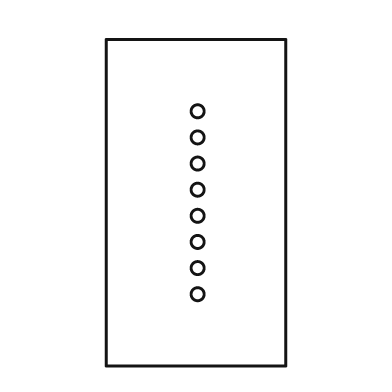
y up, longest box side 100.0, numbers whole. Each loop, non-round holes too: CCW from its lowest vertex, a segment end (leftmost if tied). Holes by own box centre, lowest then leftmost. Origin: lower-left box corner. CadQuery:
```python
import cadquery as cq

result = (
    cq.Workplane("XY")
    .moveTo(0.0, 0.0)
    .lineTo(55.0, 0.0)
    .lineTo(55.0, 100.0)
    .lineTo(0.0, 100.0)
    .close()
    .moveTo(28.0, 22.0)
    .circle(2.0)
    .moveTo(28.0, 30.0)
    .circle(2.0)
    .moveTo(28.0, 38.0)
    .circle(2.0)
    .moveTo(28.0, 46.0)
    .circle(2.0)
    .moveTo(28.0, 54.0)
    .circle(2.0)
    .moveTo(28.0, 62.0)
    .circle(2.0)
    .moveTo(28.0, 70.0)
    .circle(2.0)
    .moveTo(28.0, 78.0)
    .circle(2.0)
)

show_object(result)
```